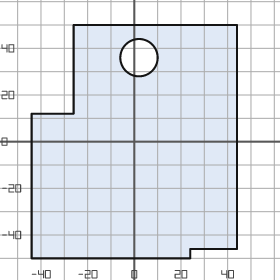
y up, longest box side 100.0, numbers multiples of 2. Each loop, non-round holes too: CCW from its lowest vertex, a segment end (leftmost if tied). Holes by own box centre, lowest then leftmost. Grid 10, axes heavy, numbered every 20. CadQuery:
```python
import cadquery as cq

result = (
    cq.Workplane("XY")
    .moveTo(-44.0, -50.0)
    .lineTo(24.0, -50.0)
    .lineTo(24.0, -46.0)
    .lineTo(44.0, -46.0)
    .lineTo(44.0, 50.0)
    .lineTo(-26.0, 50.0)
    .lineTo(-26.0, 12.0)
    .lineTo(-44.0, 12.0)
    .close()
    .moveTo(2.0, 36.0)
    .circle(8.0)
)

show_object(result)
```